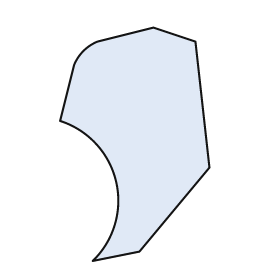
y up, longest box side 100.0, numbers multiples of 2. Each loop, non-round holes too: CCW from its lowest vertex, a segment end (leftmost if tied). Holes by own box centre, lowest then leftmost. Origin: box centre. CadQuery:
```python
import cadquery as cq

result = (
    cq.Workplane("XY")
    .moveTo(-18.0, -50.0)
    .lineTo(2.0, -46.0)
    .lineTo(32.0, -10.0)
    .lineTo(26.0, 44.0)
    .lineTo(8.0, 50.0)
    .lineTo(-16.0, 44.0)
    .threePointArc((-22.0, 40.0), (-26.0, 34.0))
    .lineTo(-32.0, 10.0)
    .threePointArc((-8.0, -16.0), (-18.0, -50.0))
    .close()
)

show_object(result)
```